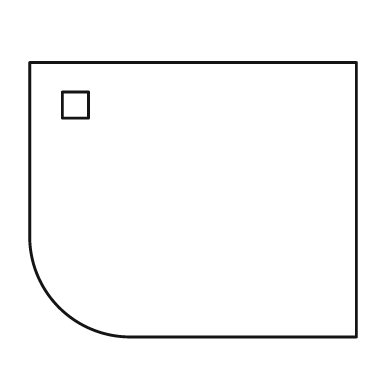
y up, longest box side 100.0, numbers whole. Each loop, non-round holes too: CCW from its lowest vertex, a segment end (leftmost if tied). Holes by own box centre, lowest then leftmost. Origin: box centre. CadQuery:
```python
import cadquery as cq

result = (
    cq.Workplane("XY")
    .moveTo(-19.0, -42.0)
    .lineTo(50.0, -42.0)
    .lineTo(50.0, 42.0)
    .lineTo(-50.0, 42.0)
    .lineTo(-50.0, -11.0)
    .threePointArc((-41.0, -33.0), (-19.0, -42.0))
    .close()
    .moveTo(-40.0, 25.0)
    .lineTo(-32.0, 25.0)
    .lineTo(-32.0, 33.0)
    .lineTo(-40.0, 33.0)
    .close()
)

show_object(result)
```